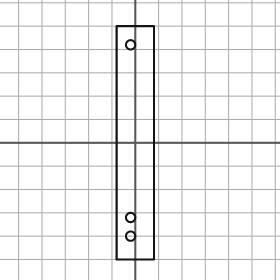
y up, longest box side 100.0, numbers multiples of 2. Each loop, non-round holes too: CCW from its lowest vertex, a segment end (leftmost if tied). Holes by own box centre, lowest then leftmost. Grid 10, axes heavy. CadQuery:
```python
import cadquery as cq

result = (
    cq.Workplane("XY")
    .moveTo(-8.0, -50.0)
    .lineTo(8.0, -50.0)
    .lineTo(8.0, 50.0)
    .lineTo(-8.0, 50.0)
    .close()
    .moveTo(-2.0, -40.0)
    .circle(2.0)
    .moveTo(-2.0, -32.0)
    .circle(2.0)
    .moveTo(-2.0, 42.0)
    .circle(2.0)
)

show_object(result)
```